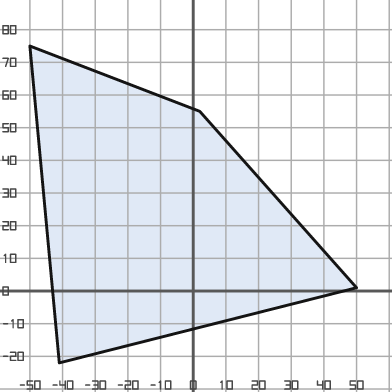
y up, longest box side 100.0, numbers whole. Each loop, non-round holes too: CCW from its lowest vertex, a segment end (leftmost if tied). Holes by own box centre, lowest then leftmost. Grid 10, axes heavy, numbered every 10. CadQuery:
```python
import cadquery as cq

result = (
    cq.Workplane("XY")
    .moveTo(-41.0, -22.0)
    .lineTo(50.0, 1.0)
    .lineTo(2.0, 55.0)
    .lineTo(-50.0, 75.0)
    .close()
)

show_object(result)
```